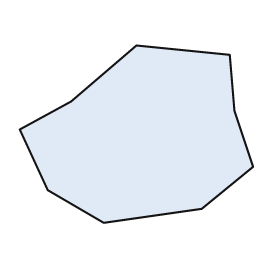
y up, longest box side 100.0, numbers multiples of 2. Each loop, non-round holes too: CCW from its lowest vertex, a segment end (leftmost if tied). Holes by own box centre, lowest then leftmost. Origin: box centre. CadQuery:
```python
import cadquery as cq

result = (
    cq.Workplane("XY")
    .moveTo(-14.0, -38.0)
    .lineTo(28.0, -32.0)
    .lineTo(50.0, -14.0)
    .lineTo(42.0, 10.0)
    .lineTo(40.0, 34.0)
    .lineTo(0.0, 38.0)
    .lineTo(-28.0, 14.0)
    .lineTo(-50.0, 2.0)
    .lineTo(-38.0, -24.0)
    .close()
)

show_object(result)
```